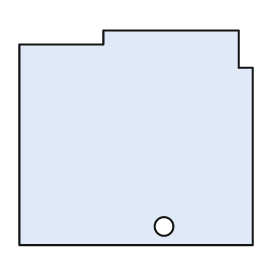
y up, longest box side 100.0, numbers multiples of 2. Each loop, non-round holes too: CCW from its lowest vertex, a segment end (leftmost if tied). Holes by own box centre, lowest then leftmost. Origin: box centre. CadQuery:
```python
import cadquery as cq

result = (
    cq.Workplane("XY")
    .moveTo(-50.0, -46.0)
    .lineTo(50.0, -46.0)
    .lineTo(50.0, 30.0)
    .lineTo(44.0, 30.0)
    .lineTo(44.0, 46.0)
    .lineTo(-14.0, 46.0)
    .lineTo(-14.0, 40.0)
    .lineTo(-50.0, 40.0)
    .close()
    .moveTo(12.0, -38.0)
    .circle(4.0)
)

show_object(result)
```